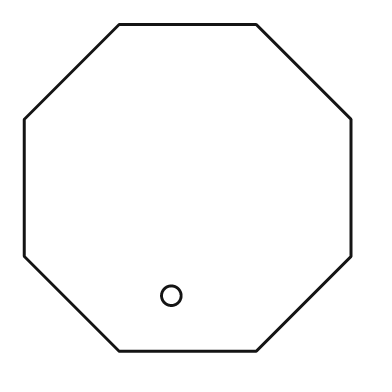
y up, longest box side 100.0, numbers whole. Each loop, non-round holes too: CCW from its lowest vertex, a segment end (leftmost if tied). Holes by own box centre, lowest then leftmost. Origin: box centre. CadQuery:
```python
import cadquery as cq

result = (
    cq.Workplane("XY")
    .moveTo(-21.0, -50.0)
    .lineTo(21.0, -50.0)
    .lineTo(50.0, -21.0)
    .lineTo(50.0, 21.0)
    .lineTo(21.0, 50.0)
    .lineTo(-21.0, 50.0)
    .lineTo(-50.0, 21.0)
    .lineTo(-50.0, -21.0)
    .close()
    .moveTo(-5.0, -33.0)
    .circle(3.0)
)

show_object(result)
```